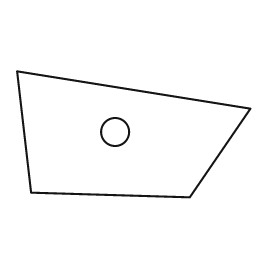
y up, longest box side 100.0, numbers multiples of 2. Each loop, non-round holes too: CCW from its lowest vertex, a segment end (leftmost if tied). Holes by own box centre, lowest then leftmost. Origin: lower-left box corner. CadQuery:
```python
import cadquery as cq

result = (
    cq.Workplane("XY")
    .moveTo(74.0, 0.0)
    .lineTo(100.0, 38.0)
    .lineTo(0.0, 54.0)
    .lineTo(6.0, 2.0)
    .close()
    .moveTo(42.0, 28.0)
    .circle(6.0)
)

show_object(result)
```